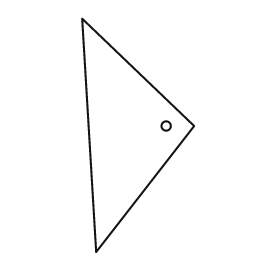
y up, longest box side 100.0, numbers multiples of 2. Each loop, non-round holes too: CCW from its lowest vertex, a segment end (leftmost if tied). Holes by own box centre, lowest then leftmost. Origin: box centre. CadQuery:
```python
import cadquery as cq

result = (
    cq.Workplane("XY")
    .moveTo(-18.0, -50.0)
    .lineTo(24.0, 4.0)
    .lineTo(-24.0, 50.0)
    .close()
    .moveTo(12.0, 4.0)
    .circle(2.0)
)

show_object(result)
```